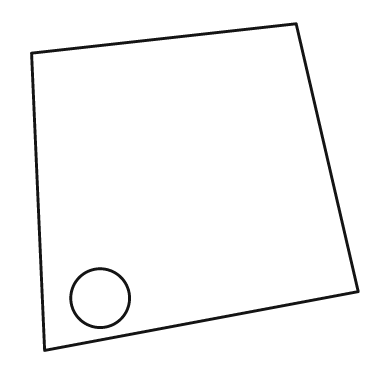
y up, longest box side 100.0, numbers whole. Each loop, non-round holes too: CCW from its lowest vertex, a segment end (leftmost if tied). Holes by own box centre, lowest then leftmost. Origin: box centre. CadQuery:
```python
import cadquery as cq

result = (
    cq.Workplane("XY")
    .moveTo(-46.0, -50.0)
    .lineTo(50.0, -32.0)
    .lineTo(31.0, 50.0)
    .lineTo(-50.0, 41.0)
    .close()
    .moveTo(-29.0, -34.0)
    .circle(9.0)
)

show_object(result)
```